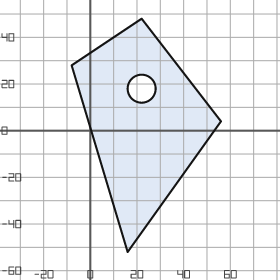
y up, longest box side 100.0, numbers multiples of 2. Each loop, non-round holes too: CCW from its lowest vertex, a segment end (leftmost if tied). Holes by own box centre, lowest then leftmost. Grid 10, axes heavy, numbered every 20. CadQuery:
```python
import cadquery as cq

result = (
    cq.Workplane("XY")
    .moveTo(16.0, -52.0)
    .lineTo(56.0, 4.0)
    .lineTo(22.0, 48.0)
    .lineTo(-8.0, 28.0)
    .close()
    .moveTo(22.0, 18.0)
    .circle(6.0)
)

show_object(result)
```